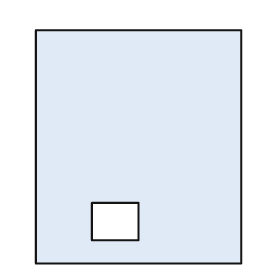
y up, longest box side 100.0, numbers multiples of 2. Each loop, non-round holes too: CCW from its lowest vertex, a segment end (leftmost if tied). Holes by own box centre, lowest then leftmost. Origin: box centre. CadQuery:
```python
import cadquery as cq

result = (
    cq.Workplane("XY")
    .moveTo(-44.0, -50.0)
    .lineTo(44.0, -50.0)
    .lineTo(44.0, 50.0)
    .lineTo(-44.0, 50.0)
    .close()
    .moveTo(-20.0, -40.0)
    .lineTo(0.0, -40.0)
    .lineTo(0.0, -24.0)
    .lineTo(-20.0, -24.0)
    .close()
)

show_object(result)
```